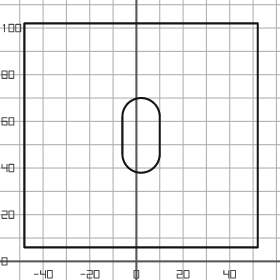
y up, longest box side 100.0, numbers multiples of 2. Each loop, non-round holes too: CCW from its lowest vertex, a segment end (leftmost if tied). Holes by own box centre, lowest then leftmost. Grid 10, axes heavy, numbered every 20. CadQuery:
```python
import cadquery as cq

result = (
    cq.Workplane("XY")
    .moveTo(-48.0, 6.0)
    .lineTo(52.0, 6.0)
    .lineTo(52.0, 102.0)
    .lineTo(-48.0, 102.0)
    .close()
    .moveTo(-6.0, 46.0)
    .threePointArc((2.0, 38.0), (10.0, 46.0))
    .lineTo(10.0, 62.0)
    .threePointArc((2.0, 70.0), (-6.0, 62.0))
    .close()
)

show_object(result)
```